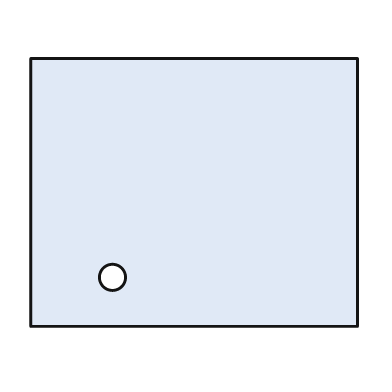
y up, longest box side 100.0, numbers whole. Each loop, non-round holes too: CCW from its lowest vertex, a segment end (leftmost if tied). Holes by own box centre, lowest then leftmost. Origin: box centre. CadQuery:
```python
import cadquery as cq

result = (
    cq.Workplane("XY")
    .moveTo(-50.0, -41.0)
    .lineTo(50.0, -41.0)
    .lineTo(50.0, 41.0)
    .lineTo(-50.0, 41.0)
    .close()
    .moveTo(-25.0, -26.0)
    .circle(4.0)
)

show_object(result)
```